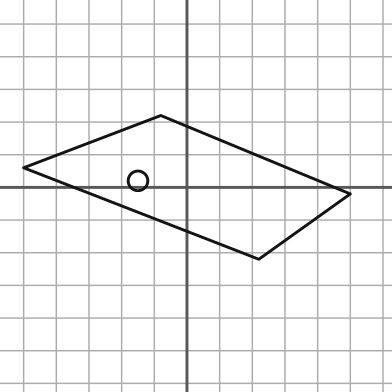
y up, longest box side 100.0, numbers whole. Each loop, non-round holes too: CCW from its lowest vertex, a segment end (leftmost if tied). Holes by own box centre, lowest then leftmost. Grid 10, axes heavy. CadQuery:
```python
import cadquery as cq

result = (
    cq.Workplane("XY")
    .moveTo(22.0, -22.0)
    .lineTo(50.0, -2.0)
    .lineTo(-8.0, 22.0)
    .lineTo(-50.0, 6.0)
    .close()
    .moveTo(-15.0, 2.0)
    .circle(3.0)
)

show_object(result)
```